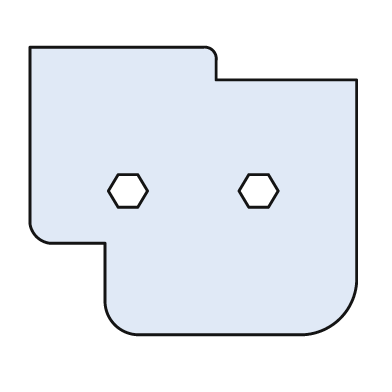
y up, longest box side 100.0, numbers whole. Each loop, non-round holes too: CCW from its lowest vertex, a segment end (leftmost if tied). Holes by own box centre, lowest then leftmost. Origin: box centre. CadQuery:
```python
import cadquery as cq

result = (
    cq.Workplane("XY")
    .moveTo(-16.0, -44.0)
    .lineTo(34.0, -44.0)
    .threePointArc((45.0, -39.0), (50.0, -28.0))
    .lineTo(50.0, 34.0)
    .lineTo(7.0, 34.0)
    .lineTo(7.0, 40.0)
    .threePointArc((6.0, 43.0), (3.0, 44.0))
    .lineTo(-50.0, 44.0)
    .lineTo(-50.0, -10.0)
    .threePointArc((-48.0, -14.0), (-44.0, -16.0))
    .lineTo(-27.0, -16.0)
    .lineTo(-27.0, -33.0)
    .threePointArc((-24.0, -41.0), (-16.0, -44.0))
    .close()
    .moveTo(-23.0, -5.0)
    .lineTo(-17.0, -5.0)
    .lineTo(-14.0, 0.0)
    .lineTo(-17.0, 5.0)
    .lineTo(-23.0, 5.0)
    .lineTo(-26.0, 0.0)
    .close()
    .moveTo(17.0, -5.0)
    .lineTo(23.0, -5.0)
    .lineTo(26.0, 0.0)
    .lineTo(23.0, 5.0)
    .lineTo(17.0, 5.0)
    .lineTo(14.0, 0.0)
    .close()
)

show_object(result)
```